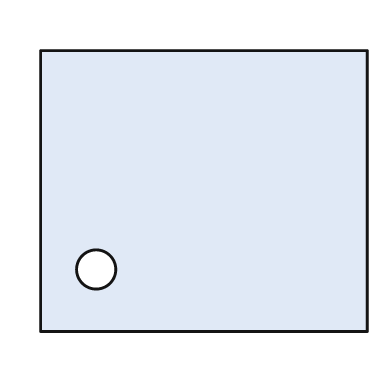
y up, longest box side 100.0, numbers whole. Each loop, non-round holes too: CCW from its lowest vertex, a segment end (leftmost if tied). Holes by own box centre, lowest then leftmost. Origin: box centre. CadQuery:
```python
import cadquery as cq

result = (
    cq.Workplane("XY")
    .moveTo(-50.0, -43.0)
    .lineTo(50.0, -43.0)
    .lineTo(50.0, 43.0)
    .lineTo(-50.0, 43.0)
    .close()
    .moveTo(-33.0, -24.0)
    .circle(6.0)
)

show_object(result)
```